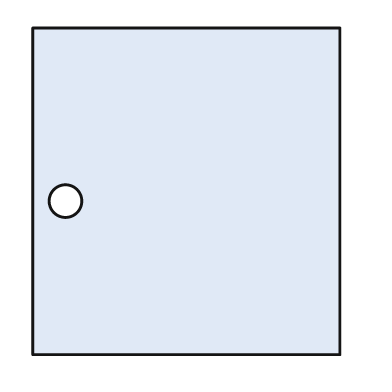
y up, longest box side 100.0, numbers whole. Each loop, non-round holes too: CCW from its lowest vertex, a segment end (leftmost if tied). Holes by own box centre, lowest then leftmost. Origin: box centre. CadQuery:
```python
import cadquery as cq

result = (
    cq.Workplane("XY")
    .moveTo(-47.0, -50.0)
    .lineTo(47.0, -50.0)
    .lineTo(47.0, 50.0)
    .lineTo(-47.0, 50.0)
    .close()
    .moveTo(-37.0, -3.0)
    .circle(5.0)
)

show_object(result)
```